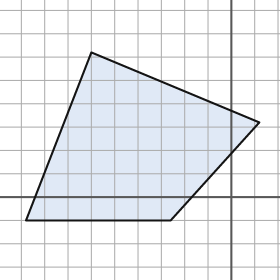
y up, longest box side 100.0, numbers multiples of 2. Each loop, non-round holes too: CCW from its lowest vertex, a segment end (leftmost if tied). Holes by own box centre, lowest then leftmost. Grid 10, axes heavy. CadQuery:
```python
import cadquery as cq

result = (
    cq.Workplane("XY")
    .moveTo(-88.0, -10.0)
    .lineTo(-26.0, -10.0)
    .lineTo(12.0, 32.0)
    .lineTo(-60.0, 62.0)
    .close()
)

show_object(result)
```